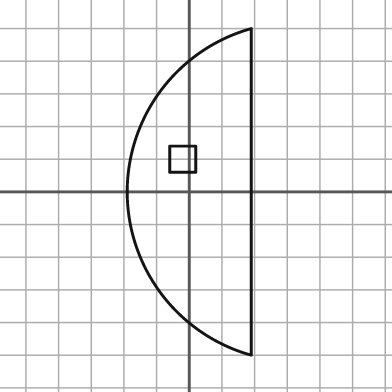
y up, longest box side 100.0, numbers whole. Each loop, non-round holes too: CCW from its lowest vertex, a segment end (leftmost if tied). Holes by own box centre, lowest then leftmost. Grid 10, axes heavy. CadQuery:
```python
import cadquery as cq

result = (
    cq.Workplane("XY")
    .moveTo(19.0, -50.0)
    .lineTo(19.0, 50.0)
    .threePointArc((-19.0, 0.0), (19.0, -50.0))
    .close()
    .moveTo(-6.0, 6.0)
    .lineTo(2.0, 6.0)
    .lineTo(2.0, 14.0)
    .lineTo(-6.0, 14.0)
    .close()
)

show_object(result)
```